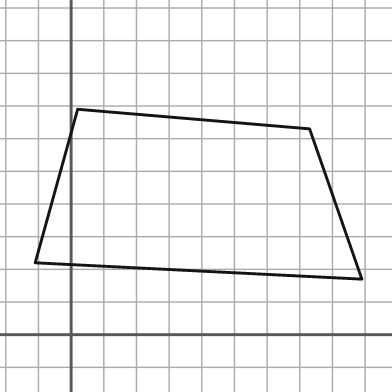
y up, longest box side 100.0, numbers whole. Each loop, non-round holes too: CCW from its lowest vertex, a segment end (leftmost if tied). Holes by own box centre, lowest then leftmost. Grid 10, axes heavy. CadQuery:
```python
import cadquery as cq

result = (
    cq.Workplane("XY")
    .moveTo(89.0, 17.0)
    .lineTo(73.0, 63.0)
    .lineTo(2.0, 69.0)
    .lineTo(-11.0, 22.0)
    .close()
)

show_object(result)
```